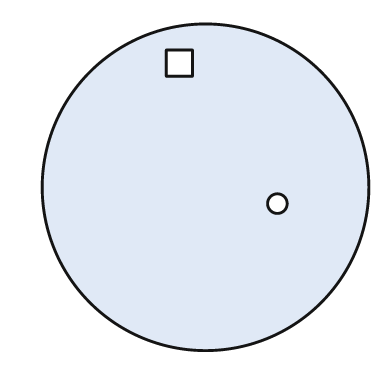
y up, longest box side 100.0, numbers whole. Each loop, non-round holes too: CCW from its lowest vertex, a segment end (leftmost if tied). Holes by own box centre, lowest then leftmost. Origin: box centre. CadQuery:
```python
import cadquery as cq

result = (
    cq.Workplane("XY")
    .moveTo(0.0, 0.0)
    .circle(50.0)
    .moveTo(22.0, -5.0)
    .circle(3.0)
    .moveTo(-12.0, 34.0)
    .lineTo(-4.0, 34.0)
    .lineTo(-4.0, 42.0)
    .lineTo(-12.0, 42.0)
    .close()
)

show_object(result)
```